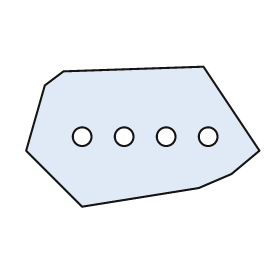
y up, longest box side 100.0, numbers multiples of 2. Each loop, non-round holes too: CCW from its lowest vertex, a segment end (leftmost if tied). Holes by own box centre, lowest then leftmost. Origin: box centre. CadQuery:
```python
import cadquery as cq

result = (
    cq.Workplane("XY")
    .moveTo(-26.0, -30.0)
    .lineTo(24.0, -22.0)
    .lineTo(38.0, -16.0)
    .lineTo(50.0, -6.0)
    .lineTo(26.0, 30.0)
    .lineTo(-34.0, 28.0)
    .lineTo(-42.0, 22.0)
    .lineTo(-50.0, -6.0)
    .close()
    .moveTo(-26.0, 0.0)
    .circle(4.0)
    .moveTo(-8.0, 0.0)
    .circle(4.0)
    .moveTo(10.0, 0.0)
    .circle(4.0)
    .moveTo(28.0, 0.0)
    .circle(4.0)
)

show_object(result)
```